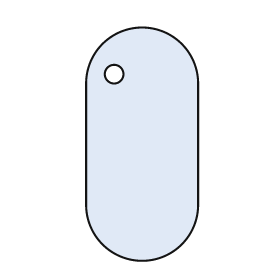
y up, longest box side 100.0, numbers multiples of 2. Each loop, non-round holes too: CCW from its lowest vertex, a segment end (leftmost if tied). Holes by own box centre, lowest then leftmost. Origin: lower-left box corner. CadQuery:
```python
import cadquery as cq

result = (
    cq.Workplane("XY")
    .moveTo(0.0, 24.0)
    .threePointArc((24.0, 0.0), (48.0, 24.0))
    .lineTo(48.0, 76.0)
    .threePointArc((24.0, 100.0), (0.0, 76.0))
    .close()
    .moveTo(12.0, 80.0)
    .circle(4.0)
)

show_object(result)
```